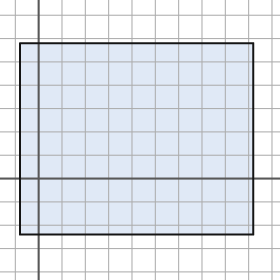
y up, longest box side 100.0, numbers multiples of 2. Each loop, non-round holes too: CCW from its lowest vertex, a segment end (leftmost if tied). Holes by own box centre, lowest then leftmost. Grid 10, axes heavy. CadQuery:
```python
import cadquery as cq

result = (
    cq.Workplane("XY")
    .moveTo(-8.0, -24.0)
    .lineTo(92.0, -24.0)
    .lineTo(92.0, 58.0)
    .lineTo(-8.0, 58.0)
    .close()
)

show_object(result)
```